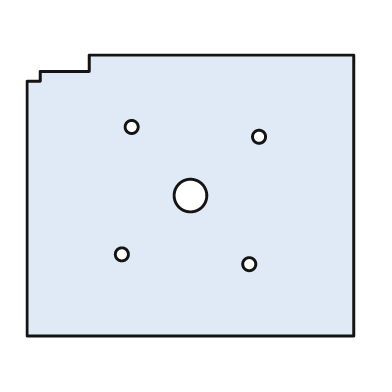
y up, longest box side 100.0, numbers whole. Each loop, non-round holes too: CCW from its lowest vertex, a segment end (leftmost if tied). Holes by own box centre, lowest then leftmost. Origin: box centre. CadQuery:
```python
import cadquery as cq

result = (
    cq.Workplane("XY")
    .moveTo(-50.0, -43.0)
    .lineTo(50.0, -43.0)
    .lineTo(50.0, 43.0)
    .lineTo(-31.0, 43.0)
    .lineTo(-31.0, 38.0)
    .lineTo(-46.0, 38.0)
    .lineTo(-46.0, 35.0)
    .lineTo(-50.0, 35.0)
    .close()
    .moveTo(18.0, -21.0)
    .circle(2.0)
    .moveTo(-21.0, -18.0)
    .circle(2.0)
    .moveTo(0.0, 0.0)
    .circle(5.0)
    .moveTo(21.0, 18.0)
    .circle(2.0)
    .moveTo(-18.0, 21.0)
    .circle(2.0)
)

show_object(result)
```